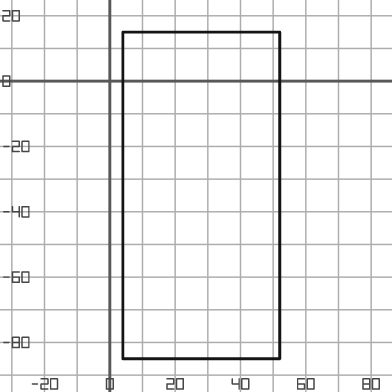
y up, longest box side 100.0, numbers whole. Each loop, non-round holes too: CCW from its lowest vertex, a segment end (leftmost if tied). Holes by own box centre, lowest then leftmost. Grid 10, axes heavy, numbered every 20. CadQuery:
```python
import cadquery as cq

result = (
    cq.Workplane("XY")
    .moveTo(4.0, -85.0)
    .lineTo(52.0, -85.0)
    .lineTo(52.0, 15.0)
    .lineTo(4.0, 15.0)
    .close()
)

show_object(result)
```